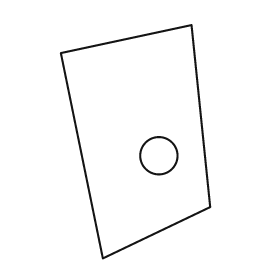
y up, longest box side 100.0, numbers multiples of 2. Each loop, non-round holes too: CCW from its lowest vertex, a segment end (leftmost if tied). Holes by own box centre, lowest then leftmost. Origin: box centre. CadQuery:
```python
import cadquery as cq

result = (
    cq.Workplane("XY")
    .moveTo(-14.0, -50.0)
    .lineTo(32.0, -28.0)
    .lineTo(24.0, 50.0)
    .lineTo(-32.0, 38.0)
    .close()
    .moveTo(10.0, -6.0)
    .circle(8.0)
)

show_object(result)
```